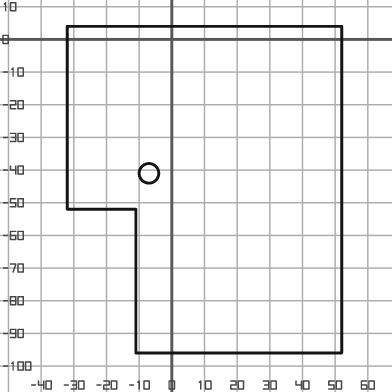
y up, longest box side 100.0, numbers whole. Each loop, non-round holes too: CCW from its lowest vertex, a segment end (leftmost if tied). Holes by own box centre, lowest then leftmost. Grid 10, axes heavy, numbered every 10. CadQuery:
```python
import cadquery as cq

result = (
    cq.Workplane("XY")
    .moveTo(-11.0, -96.0)
    .lineTo(52.0, -96.0)
    .lineTo(52.0, 4.0)
    .lineTo(-32.0, 4.0)
    .lineTo(-32.0, -52.0)
    .lineTo(-11.0, -52.0)
    .close()
    .moveTo(-7.0, -41.0)
    .circle(3.0)
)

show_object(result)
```